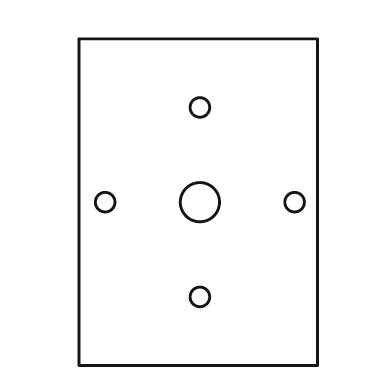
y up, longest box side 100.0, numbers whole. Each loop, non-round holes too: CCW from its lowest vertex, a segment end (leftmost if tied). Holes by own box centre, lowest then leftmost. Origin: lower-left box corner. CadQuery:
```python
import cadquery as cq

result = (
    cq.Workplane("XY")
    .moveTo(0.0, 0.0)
    .lineTo(73.0, 0.0)
    .lineTo(73.0, 100.0)
    .lineTo(0.0, 100.0)
    .close()
    .moveTo(37.0, 21.0)
    .circle(3.0)
    .moveTo(8.0, 50.0)
    .circle(3.0)
    .moveTo(37.0, 50.0)
    .circle(6.0)
    .moveTo(66.0, 50.0)
    .circle(3.0)
    .moveTo(37.0, 79.0)
    .circle(3.0)
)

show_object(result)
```